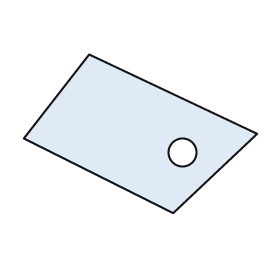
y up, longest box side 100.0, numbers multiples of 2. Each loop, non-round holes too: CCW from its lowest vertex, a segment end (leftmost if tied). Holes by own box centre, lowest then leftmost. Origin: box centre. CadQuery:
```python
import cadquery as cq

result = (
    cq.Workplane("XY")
    .moveTo(14.0, -34.0)
    .lineTo(50.0, 0.0)
    .lineTo(-22.0, 34.0)
    .lineTo(-50.0, -2.0)
    .close()
    .moveTo(18.0, -8.0)
    .circle(6.0)
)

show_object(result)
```